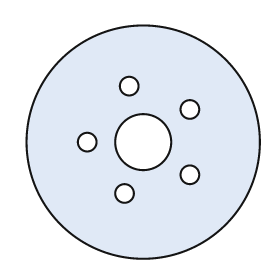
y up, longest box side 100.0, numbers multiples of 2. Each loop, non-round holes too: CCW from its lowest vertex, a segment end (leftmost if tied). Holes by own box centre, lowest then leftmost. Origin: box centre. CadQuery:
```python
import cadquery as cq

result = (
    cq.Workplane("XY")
    .moveTo(0.0, 0.0)
    .circle(50.0)
    .moveTo(-8.0, -22.0)
    .circle(4.0)
    .moveTo(20.0, -14.0)
    .circle(4.0)
    .moveTo(-24.0, 0.0)
    .circle(4.0)
    .moveTo(0.0, 0.0)
    .circle(12.0)
    .moveTo(20.0, 14.0)
    .circle(4.0)
    .moveTo(-6.0, 24.0)
    .circle(4.0)
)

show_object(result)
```